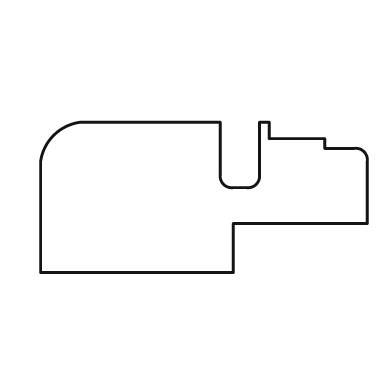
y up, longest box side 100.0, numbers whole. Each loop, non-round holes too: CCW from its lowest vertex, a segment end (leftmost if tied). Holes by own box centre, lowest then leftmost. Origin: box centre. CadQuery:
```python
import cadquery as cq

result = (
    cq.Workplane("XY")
    .moveTo(-50.0, -23.0)
    .lineTo(9.0, -23.0)
    .lineTo(9.0, -8.0)
    .lineTo(50.0, -8.0)
    .lineTo(50.0, 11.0)
    .threePointArc((49.0, 14.0), (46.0, 15.0))
    .lineTo(37.0, 15.0)
    .lineTo(37.0, 18.0)
    .lineTo(20.0, 18.0)
    .lineTo(20.0, 23.0)
    .lineTo(17.0, 23.0)
    .lineTo(17.0, 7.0)
    .threePointArc((16.0, 4.0), (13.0, 3.0))
    .lineTo(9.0, 3.0)
    .threePointArc((6.0, 4.0), (5.0, 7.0))
    .lineTo(5.0, 23.0)
    .lineTo(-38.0, 23.0)
    .threePointArc((-46.0, 19.0), (-50.0, 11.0))
    .close()
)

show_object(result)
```